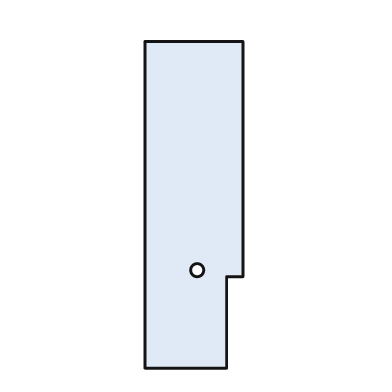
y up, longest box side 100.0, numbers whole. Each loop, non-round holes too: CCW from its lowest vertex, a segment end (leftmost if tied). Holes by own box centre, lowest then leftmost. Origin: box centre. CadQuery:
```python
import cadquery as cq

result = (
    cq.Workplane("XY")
    .moveTo(-15.0, -50.0)
    .lineTo(10.0, -50.0)
    .lineTo(10.0, -22.0)
    .lineTo(15.0, -22.0)
    .lineTo(15.0, 50.0)
    .lineTo(-15.0, 50.0)
    .close()
    .moveTo(1.0, -20.0)
    .circle(2.0)
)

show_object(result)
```